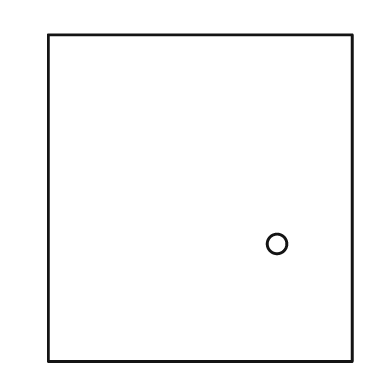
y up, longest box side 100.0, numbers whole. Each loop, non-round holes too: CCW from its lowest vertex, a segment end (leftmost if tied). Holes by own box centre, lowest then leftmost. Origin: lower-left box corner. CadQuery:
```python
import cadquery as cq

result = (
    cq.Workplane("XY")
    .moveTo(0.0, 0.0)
    .lineTo(93.0, 0.0)
    .lineTo(93.0, 100.0)
    .lineTo(0.0, 100.0)
    .close()
    .moveTo(70.0, 36.0)
    .circle(3.0)
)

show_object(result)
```